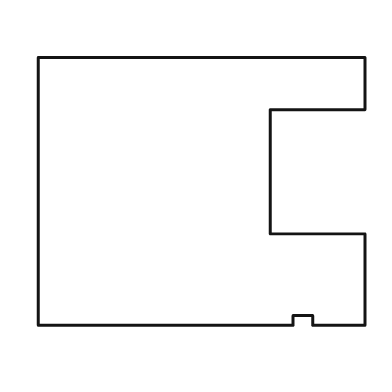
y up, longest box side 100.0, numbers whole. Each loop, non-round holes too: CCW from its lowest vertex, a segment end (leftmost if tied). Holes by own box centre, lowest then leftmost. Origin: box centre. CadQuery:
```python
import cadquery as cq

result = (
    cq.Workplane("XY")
    .moveTo(-50.0, -41.0)
    .lineTo(28.0, -41.0)
    .lineTo(28.0, -38.0)
    .lineTo(34.0, -38.0)
    .lineTo(34.0, -41.0)
    .lineTo(50.0, -41.0)
    .lineTo(50.0, -13.0)
    .lineTo(21.0, -13.0)
    .lineTo(21.0, 25.0)
    .lineTo(50.0, 25.0)
    .lineTo(50.0, 41.0)
    .lineTo(-50.0, 41.0)
    .close()
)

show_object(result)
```